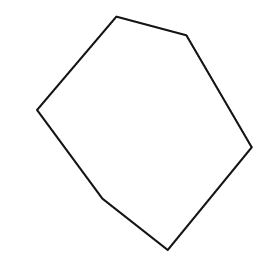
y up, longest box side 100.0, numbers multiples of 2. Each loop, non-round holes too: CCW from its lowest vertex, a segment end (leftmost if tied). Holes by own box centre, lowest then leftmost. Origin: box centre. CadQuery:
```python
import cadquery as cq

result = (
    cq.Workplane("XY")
    .moveTo(10.0, -50.0)
    .lineTo(46.0, -6.0)
    .lineTo(18.0, 42.0)
    .lineTo(-12.0, 50.0)
    .lineTo(-46.0, 10.0)
    .lineTo(-18.0, -28.0)
    .close()
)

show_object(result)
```